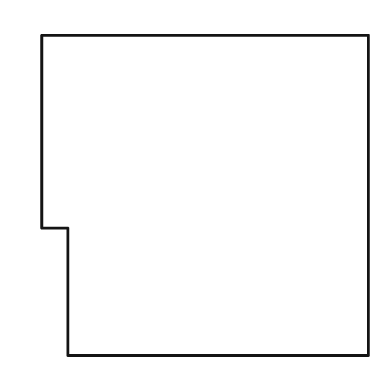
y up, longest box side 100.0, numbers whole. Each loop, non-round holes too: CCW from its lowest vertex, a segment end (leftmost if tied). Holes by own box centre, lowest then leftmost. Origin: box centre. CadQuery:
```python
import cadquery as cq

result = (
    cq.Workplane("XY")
    .moveTo(-42.0, -49.0)
    .lineTo(50.0, -49.0)
    .lineTo(50.0, 49.0)
    .lineTo(-50.0, 49.0)
    .lineTo(-50.0, -10.0)
    .lineTo(-42.0, -10.0)
    .close()
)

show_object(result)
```